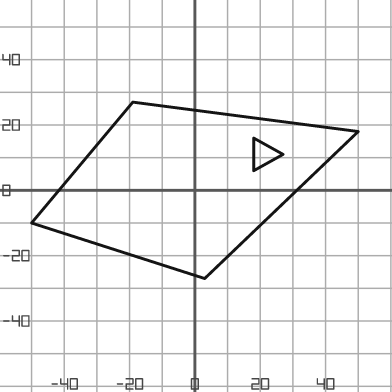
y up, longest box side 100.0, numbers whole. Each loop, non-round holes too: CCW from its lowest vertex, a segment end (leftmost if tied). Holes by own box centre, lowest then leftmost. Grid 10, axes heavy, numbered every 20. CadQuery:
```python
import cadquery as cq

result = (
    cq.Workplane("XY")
    .moveTo(3.0, -27.0)
    .lineTo(50.0, 18.0)
    .lineTo(-19.0, 27.0)
    .lineTo(-50.0, -10.0)
    .close()
    .moveTo(18.0, 6.0)
    .lineTo(27.0, 11.0)
    .lineTo(18.0, 16.0)
    .close()
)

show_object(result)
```